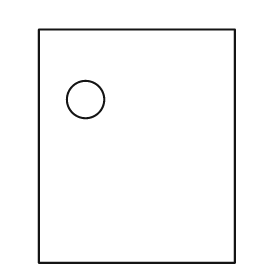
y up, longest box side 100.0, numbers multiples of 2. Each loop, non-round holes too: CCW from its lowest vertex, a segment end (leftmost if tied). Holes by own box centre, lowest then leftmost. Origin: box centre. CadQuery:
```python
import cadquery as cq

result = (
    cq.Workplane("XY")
    .moveTo(-42.0, -50.0)
    .lineTo(42.0, -50.0)
    .lineTo(42.0, 50.0)
    .lineTo(-42.0, 50.0)
    .close()
    .moveTo(-22.0, 20.0)
    .circle(8.0)
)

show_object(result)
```